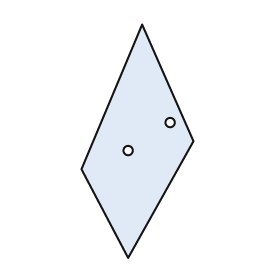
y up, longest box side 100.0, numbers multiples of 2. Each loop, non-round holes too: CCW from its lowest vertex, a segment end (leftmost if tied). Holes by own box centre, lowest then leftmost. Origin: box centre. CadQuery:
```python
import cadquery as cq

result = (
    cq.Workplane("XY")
    .moveTo(-4.0, -50.0)
    .lineTo(24.0, 0.0)
    .lineTo(2.0, 50.0)
    .lineTo(-24.0, -12.0)
    .close()
    .moveTo(-4.0, -4.0)
    .circle(2.0)
    .moveTo(14.0, 8.0)
    .circle(2.0)
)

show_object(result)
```